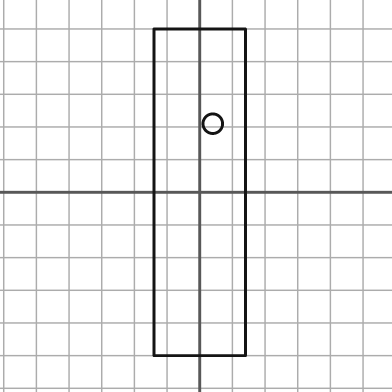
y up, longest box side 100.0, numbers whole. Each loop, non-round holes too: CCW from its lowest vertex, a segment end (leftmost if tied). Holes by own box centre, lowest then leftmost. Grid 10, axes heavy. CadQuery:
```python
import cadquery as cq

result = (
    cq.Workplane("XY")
    .moveTo(-14.0, -50.0)
    .lineTo(14.0, -50.0)
    .lineTo(14.0, 50.0)
    .lineTo(-14.0, 50.0)
    .close()
    .moveTo(4.0, 21.0)
    .circle(3.0)
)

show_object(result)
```